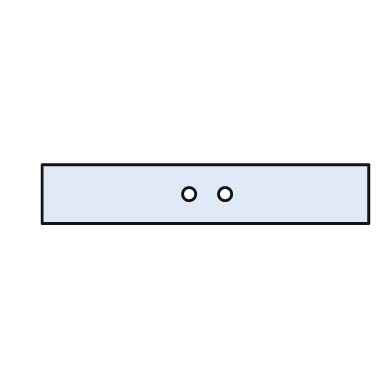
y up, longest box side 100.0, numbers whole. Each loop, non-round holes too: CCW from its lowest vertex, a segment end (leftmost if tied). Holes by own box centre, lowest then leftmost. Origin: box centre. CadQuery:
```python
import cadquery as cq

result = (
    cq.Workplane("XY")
    .moveTo(-50.0, -9.0)
    .lineTo(50.0, -9.0)
    .lineTo(50.0, 9.0)
    .lineTo(-50.0, 9.0)
    .close()
    .moveTo(-5.0, 0.0)
    .circle(2.0)
    .moveTo(6.0, 0.0)
    .circle(2.0)
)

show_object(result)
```